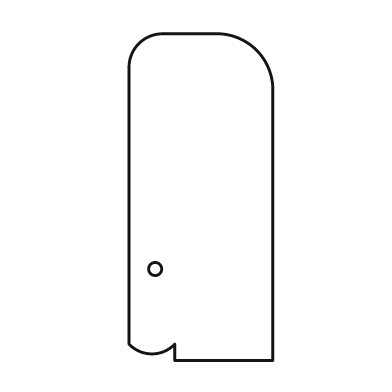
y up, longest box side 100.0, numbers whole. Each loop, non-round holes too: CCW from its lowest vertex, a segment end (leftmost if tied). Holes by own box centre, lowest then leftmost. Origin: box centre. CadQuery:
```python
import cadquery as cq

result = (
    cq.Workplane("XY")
    .moveTo(-8.0, -50.0)
    .lineTo(22.0, -50.0)
    .lineTo(22.0, 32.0)
    .threePointArc((17.0, 45.0), (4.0, 50.0))
    .lineTo(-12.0, 50.0)
    .threePointArc((-19.0, 47.0), (-22.0, 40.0))
    .lineTo(-22.0, -45.0)
    .threePointArc((-15.0, -48.0), (-8.0, -45.0))
    .close()
    .moveTo(-14.0, -22.0)
    .circle(2.0)
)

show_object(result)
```